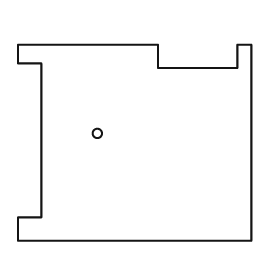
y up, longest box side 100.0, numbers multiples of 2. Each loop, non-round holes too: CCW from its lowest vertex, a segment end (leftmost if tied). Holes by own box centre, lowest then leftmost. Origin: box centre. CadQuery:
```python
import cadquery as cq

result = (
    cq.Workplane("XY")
    .moveTo(-50.0, -42.0)
    .lineTo(50.0, -42.0)
    .lineTo(50.0, 42.0)
    .lineTo(44.0, 42.0)
    .lineTo(44.0, 32.0)
    .lineTo(10.0, 32.0)
    .lineTo(10.0, 42.0)
    .lineTo(-50.0, 42.0)
    .lineTo(-50.0, 34.0)
    .lineTo(-40.0, 34.0)
    .lineTo(-40.0, -32.0)
    .lineTo(-50.0, -32.0)
    .close()
    .moveTo(-16.0, 4.0)
    .circle(2.0)
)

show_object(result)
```